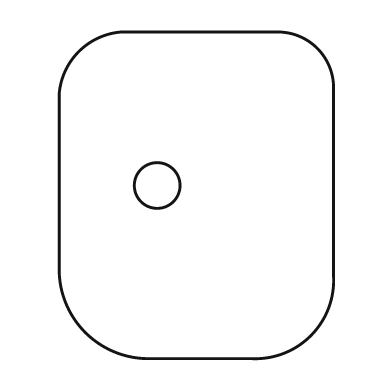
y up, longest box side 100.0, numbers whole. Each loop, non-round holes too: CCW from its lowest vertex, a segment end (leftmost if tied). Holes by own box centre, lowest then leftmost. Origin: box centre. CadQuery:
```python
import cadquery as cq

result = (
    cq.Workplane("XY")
    .moveTo(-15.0, -50.0)
    .lineTo(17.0, -50.0)
    .threePointArc((35.0, -43.0), (42.0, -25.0))
    .lineTo(42.0, 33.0)
    .threePointArc((37.0, 45.0), (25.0, 50.0))
    .lineTo(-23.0, 50.0)
    .threePointArc((-36.0, 44.0), (-42.0, 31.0))
    .lineTo(-42.0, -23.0)
    .threePointArc((-34.0, -42.0), (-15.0, -50.0))
    .close()
    .moveTo(-12.0, 3.0)
    .circle(7.0)
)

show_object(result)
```